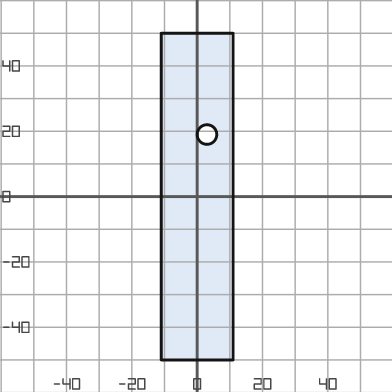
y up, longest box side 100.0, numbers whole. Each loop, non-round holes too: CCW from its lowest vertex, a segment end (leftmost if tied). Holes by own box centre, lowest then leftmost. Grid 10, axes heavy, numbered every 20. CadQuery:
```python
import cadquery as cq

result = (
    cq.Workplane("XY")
    .moveTo(-11.0, -50.0)
    .lineTo(11.0, -50.0)
    .lineTo(11.0, 50.0)
    .lineTo(-11.0, 50.0)
    .close()
    .moveTo(3.0, 19.0)
    .circle(3.0)
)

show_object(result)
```